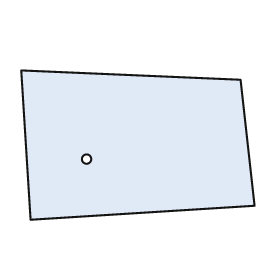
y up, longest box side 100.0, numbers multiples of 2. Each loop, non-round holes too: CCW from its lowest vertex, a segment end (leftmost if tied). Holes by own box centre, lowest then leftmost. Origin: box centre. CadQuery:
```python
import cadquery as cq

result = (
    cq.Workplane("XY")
    .moveTo(-46.0, -32.0)
    .lineTo(50.0, -26.0)
    .lineTo(44.0, 28.0)
    .lineTo(-50.0, 32.0)
    .close()
    .moveTo(-22.0, -6.0)
    .circle(2.0)
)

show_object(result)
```